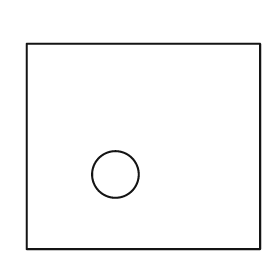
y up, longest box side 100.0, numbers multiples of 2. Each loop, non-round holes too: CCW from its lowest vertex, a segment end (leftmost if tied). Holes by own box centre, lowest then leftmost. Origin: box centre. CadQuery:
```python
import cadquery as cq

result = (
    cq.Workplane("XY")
    .moveTo(-50.0, -44.0)
    .lineTo(50.0, -44.0)
    .lineTo(50.0, 44.0)
    .lineTo(-50.0, 44.0)
    .close()
    .moveTo(-12.0, -12.0)
    .circle(10.0)
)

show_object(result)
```